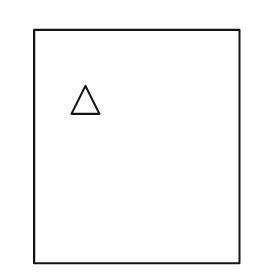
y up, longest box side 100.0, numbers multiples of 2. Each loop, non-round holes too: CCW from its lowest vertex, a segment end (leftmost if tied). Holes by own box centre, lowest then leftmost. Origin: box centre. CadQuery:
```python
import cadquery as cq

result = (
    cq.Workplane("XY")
    .moveTo(-44.0, -50.0)
    .lineTo(44.0, -50.0)
    .lineTo(44.0, 50.0)
    .lineTo(-44.0, 50.0)
    .close()
    .moveTo(-28.0, 14.0)
    .lineTo(-16.0, 14.0)
    .lineTo(-22.0, 26.0)
    .close()
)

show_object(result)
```